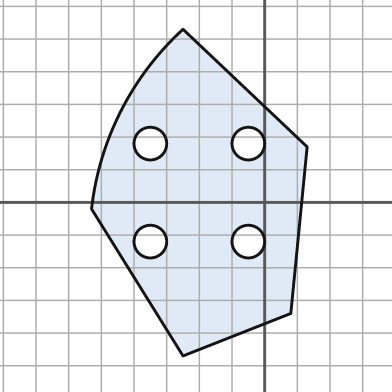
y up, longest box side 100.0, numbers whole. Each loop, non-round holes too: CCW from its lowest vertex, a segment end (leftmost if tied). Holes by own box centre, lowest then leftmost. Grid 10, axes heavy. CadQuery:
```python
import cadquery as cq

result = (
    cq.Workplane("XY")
    .moveTo(-25.0, -47.0)
    .lineTo(8.0, -34.0)
    .lineTo(13.0, 17.0)
    .lineTo(-25.0, 53.0)
    .threePointArc((-44.0, 28.0), (-53.0, -2.0))
    .close()
    .moveTo(-35.0, -12.0)
    .circle(5.0)
    .moveTo(-5.0, -12.0)
    .circle(5.0)
    .moveTo(-35.0, 18.0)
    .circle(5.0)
    .moveTo(-5.0, 18.0)
    .circle(5.0)
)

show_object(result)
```